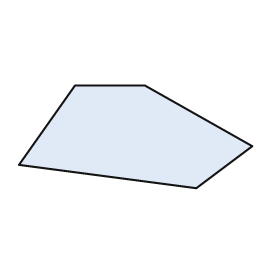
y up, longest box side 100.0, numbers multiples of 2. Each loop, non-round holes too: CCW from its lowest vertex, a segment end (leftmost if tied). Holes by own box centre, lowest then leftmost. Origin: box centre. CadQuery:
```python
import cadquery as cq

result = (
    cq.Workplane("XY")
    .moveTo(26.0, -22.0)
    .lineTo(50.0, -4.0)
    .lineTo(4.0, 22.0)
    .lineTo(-26.0, 22.0)
    .lineTo(-50.0, -12.0)
    .close()
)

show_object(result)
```